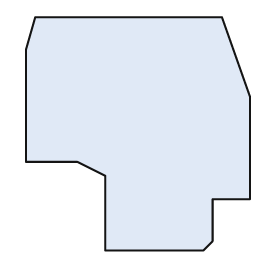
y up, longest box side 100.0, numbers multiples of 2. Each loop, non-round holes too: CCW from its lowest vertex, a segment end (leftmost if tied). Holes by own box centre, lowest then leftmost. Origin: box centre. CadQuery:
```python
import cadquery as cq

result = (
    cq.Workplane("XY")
    .moveTo(-14.0, -50.0)
    .lineTo(28.0, -50.0)
    .lineTo(32.0, -46.0)
    .lineTo(32.0, -28.0)
    .lineTo(48.0, -28.0)
    .lineTo(48.0, 16.0)
    .lineTo(36.0, 50.0)
    .lineTo(-44.0, 50.0)
    .lineTo(-48.0, 36.0)
    .lineTo(-48.0, -12.0)
    .lineTo(-26.0, -12.0)
    .lineTo(-14.0, -18.0)
    .close()
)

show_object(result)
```